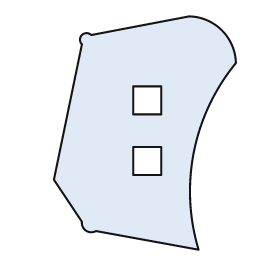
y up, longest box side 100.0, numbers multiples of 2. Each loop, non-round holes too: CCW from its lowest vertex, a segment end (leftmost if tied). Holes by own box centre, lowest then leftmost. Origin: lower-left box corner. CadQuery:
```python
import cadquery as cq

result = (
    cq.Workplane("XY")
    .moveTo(62.0, 0.0)
    .threePointArc((60.0, 42.0), (78.0, 80.0))
    .threePointArc((72.0, 94.0), (58.0, 100.0))
    .lineTo(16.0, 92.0)
    .threePointArc((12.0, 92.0), (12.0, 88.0))
    .lineTo(0.0, 30.0)
    .lineTo(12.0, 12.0)
    .threePointArc((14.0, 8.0), (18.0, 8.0))
    .close()
    .moveTo(34.0, 32.0)
    .lineTo(46.0, 32.0)
    .lineTo(46.0, 44.0)
    .lineTo(34.0, 44.0)
    .close()
    .moveTo(34.0, 58.0)
    .lineTo(46.0, 58.0)
    .lineTo(46.0, 70.0)
    .lineTo(34.0, 70.0)
    .close()
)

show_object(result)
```